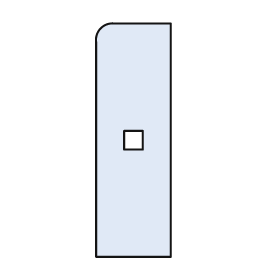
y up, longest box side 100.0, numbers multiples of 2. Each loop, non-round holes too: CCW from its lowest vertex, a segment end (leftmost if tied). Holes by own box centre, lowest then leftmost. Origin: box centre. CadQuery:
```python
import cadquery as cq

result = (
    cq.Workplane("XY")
    .moveTo(-16.0, -50.0)
    .lineTo(16.0, -50.0)
    .lineTo(16.0, 50.0)
    .lineTo(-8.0, 50.0)
    .threePointArc((-14.0, 48.0), (-16.0, 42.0))
    .close()
    .moveTo(-4.0, -4.0)
    .lineTo(4.0, -4.0)
    .lineTo(4.0, 4.0)
    .lineTo(-4.0, 4.0)
    .close()
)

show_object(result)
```